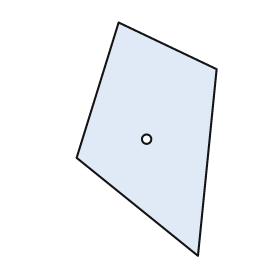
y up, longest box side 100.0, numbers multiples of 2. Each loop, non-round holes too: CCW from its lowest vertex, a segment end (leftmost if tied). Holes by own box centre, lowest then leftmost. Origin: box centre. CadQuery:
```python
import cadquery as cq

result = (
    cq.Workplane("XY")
    .moveTo(22.0, -50.0)
    .lineTo(30.0, 30.0)
    .lineTo(-12.0, 50.0)
    .lineTo(-30.0, -8.0)
    .close()
    .moveTo(0.0, 0.0)
    .circle(2.0)
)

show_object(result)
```